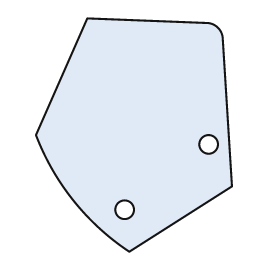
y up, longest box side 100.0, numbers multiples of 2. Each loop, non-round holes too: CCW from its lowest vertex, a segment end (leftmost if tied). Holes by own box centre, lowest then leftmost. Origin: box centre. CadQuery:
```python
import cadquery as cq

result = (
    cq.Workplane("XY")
    .moveTo(-2.0, -50.0)
    .lineTo(42.0, -22.0)
    .lineTo(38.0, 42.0)
    .threePointArc((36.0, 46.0), (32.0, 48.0))
    .lineTo(-20.0, 50.0)
    .lineTo(-42.0, 0.0)
    .threePointArc((-26.0, -28.0), (-2.0, -50.0))
    .close()
    .moveTo(-4.0, -32.0)
    .circle(4.0)
    .moveTo(32.0, -4.0)
    .circle(4.0)
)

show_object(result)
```